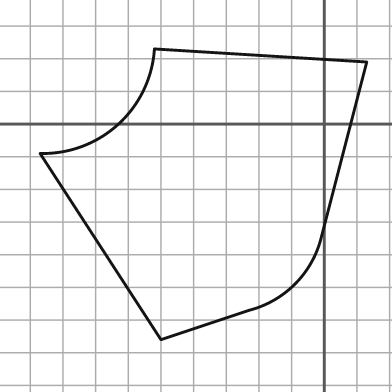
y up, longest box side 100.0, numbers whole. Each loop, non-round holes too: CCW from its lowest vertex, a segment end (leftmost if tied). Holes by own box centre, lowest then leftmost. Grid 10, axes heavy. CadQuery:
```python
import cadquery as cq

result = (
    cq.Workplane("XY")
    .moveTo(-50.0, -66.0)
    .lineTo(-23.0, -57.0)
    .threePointArc((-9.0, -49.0), (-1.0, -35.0))
    .lineTo(13.0, 19.0)
    .lineTo(-52.0, 23.0)
    .threePointArc((-63.0, 0.0), (-87.0, -9.0))
    .close()
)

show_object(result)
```